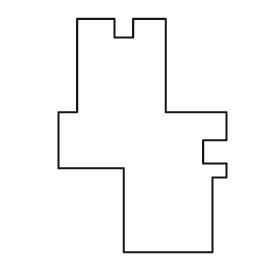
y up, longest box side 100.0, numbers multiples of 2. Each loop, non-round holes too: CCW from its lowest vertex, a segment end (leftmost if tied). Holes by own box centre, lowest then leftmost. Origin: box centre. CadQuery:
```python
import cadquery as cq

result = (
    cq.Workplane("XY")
    .moveTo(-8.0, -50.0)
    .lineTo(30.0, -50.0)
    .lineTo(30.0, -18.0)
    .lineTo(36.0, -18.0)
    .lineTo(36.0, -12.0)
    .lineTo(26.0, -12.0)
    .lineTo(26.0, -2.0)
    .lineTo(36.0, -2.0)
    .lineTo(36.0, 10.0)
    .lineTo(10.0, 10.0)
    .lineTo(10.0, 50.0)
    .lineTo(-4.0, 50.0)
    .lineTo(-4.0, 42.0)
    .lineTo(-12.0, 42.0)
    .lineTo(-12.0, 50.0)
    .lineTo(-28.0, 50.0)
    .lineTo(-28.0, 10.0)
    .lineTo(-36.0, 10.0)
    .lineTo(-36.0, -14.0)
    .lineTo(-8.0, -14.0)
    .close()
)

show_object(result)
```